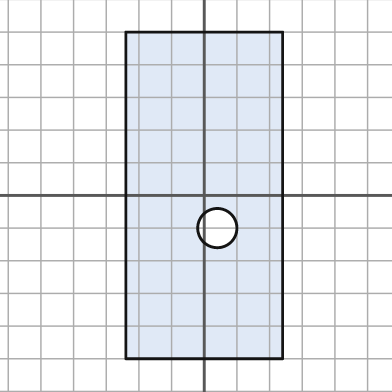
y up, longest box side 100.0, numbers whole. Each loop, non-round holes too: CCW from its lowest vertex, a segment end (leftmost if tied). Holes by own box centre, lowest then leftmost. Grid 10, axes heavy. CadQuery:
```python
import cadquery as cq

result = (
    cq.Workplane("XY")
    .moveTo(-24.0, -50.0)
    .lineTo(24.0, -50.0)
    .lineTo(24.0, 50.0)
    .lineTo(-24.0, 50.0)
    .close()
    .moveTo(4.0, -10.0)
    .circle(6.0)
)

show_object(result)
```